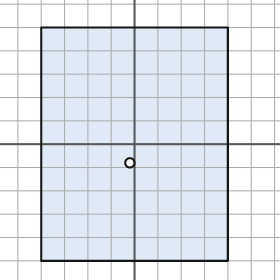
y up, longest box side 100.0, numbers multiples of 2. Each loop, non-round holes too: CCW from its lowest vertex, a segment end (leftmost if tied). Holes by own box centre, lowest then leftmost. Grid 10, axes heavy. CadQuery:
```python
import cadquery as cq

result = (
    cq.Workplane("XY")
    .moveTo(-40.0, -50.0)
    .lineTo(40.0, -50.0)
    .lineTo(40.0, 50.0)
    .lineTo(-40.0, 50.0)
    .close()
    .moveTo(-2.0, -8.0)
    .circle(2.0)
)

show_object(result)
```